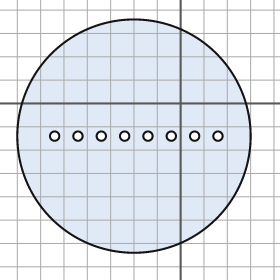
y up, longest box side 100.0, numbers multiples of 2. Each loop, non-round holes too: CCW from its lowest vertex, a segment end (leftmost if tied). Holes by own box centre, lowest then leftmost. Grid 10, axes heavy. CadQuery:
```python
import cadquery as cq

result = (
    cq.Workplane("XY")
    .moveTo(-20.0, -14.0)
    .circle(50.0)
    .moveTo(-54.0, -14.0)
    .circle(2.0)
    .moveTo(-44.0, -14.0)
    .circle(2.0)
    .moveTo(-34.0, -14.0)
    .circle(2.0)
    .moveTo(-24.0, -14.0)
    .circle(2.0)
    .moveTo(-14.0, -14.0)
    .circle(2.0)
    .moveTo(-4.0, -14.0)
    .circle(2.0)
    .moveTo(6.0, -14.0)
    .circle(2.0)
    .moveTo(16.0, -14.0)
    .circle(2.0)
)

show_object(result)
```